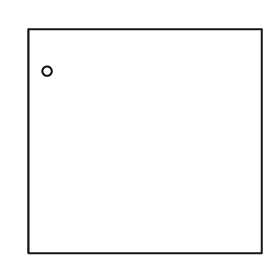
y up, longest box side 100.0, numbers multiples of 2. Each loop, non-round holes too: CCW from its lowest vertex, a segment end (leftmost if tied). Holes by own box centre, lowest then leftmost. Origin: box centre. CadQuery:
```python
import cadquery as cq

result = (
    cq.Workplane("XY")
    .moveTo(-50.0, -48.0)
    .lineTo(50.0, -48.0)
    .lineTo(50.0, 48.0)
    .lineTo(-50.0, 48.0)
    .close()
    .moveTo(-42.0, 30.0)
    .circle(2.0)
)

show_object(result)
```